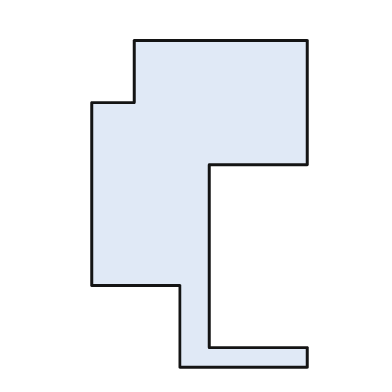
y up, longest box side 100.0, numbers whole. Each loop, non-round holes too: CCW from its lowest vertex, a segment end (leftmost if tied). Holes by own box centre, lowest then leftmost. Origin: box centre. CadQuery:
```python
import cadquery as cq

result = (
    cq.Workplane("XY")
    .moveTo(-6.0, -50.0)
    .lineTo(33.0, -50.0)
    .lineTo(33.0, -44.0)
    .lineTo(3.0, -44.0)
    .lineTo(3.0, 12.0)
    .lineTo(33.0, 12.0)
    .lineTo(33.0, 50.0)
    .lineTo(-20.0, 50.0)
    .lineTo(-20.0, 31.0)
    .lineTo(-33.0, 31.0)
    .lineTo(-33.0, -25.0)
    .lineTo(-6.0, -25.0)
    .close()
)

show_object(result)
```